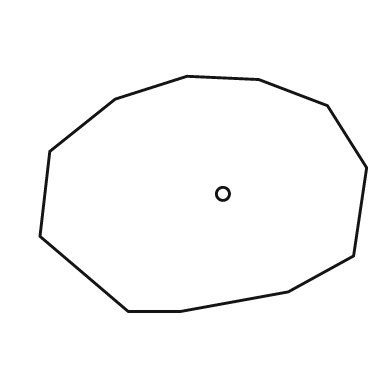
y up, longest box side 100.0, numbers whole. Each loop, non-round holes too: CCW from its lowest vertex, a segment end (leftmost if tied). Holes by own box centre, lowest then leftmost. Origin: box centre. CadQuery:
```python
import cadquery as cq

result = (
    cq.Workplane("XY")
    .moveTo(-23.0, -36.0)
    .lineTo(-7.0, -36.0)
    .lineTo(26.0, -30.0)
    .lineTo(46.0, -19.0)
    .lineTo(50.0, 8.0)
    .lineTo(38.0, 27.0)
    .lineTo(17.0, 35.0)
    .lineTo(-5.0, 36.0)
    .lineTo(-27.0, 29.0)
    .lineTo(-47.0, 13.0)
    .lineTo(-50.0, -13.0)
    .close()
    .moveTo(6.0, 0.0)
    .circle(2.0)
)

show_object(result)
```